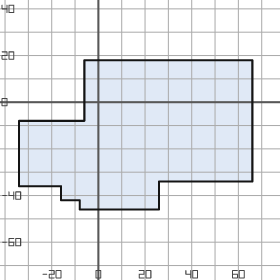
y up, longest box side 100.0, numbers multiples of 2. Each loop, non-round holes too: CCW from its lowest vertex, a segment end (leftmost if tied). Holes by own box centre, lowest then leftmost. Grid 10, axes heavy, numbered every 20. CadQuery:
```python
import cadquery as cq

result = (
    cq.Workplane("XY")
    .moveTo(-8.0, -46.0)
    .lineTo(26.0, -46.0)
    .lineTo(26.0, -34.0)
    .lineTo(66.0, -34.0)
    .lineTo(66.0, 18.0)
    .lineTo(-6.0, 18.0)
    .lineTo(-6.0, -8.0)
    .lineTo(-34.0, -8.0)
    .lineTo(-34.0, -36.0)
    .lineTo(-16.0, -36.0)
    .lineTo(-16.0, -42.0)
    .lineTo(-8.0, -42.0)
    .close()
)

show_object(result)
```